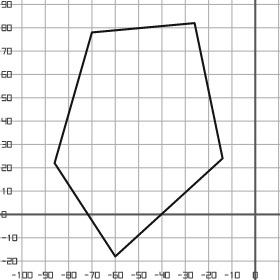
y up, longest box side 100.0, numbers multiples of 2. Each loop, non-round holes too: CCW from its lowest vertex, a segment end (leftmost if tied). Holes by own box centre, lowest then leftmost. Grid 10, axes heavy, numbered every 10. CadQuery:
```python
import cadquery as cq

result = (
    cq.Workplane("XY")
    .moveTo(-60.0, -18.0)
    .lineTo(-14.0, 24.0)
    .lineTo(-26.0, 82.0)
    .lineTo(-70.0, 78.0)
    .lineTo(-86.0, 22.0)
    .close()
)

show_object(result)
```